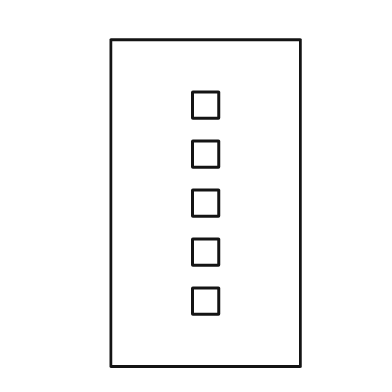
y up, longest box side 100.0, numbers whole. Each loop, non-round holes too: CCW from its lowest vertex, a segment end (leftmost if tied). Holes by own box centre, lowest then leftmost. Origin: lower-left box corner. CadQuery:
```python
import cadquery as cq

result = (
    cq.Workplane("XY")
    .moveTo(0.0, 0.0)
    .lineTo(58.0, 0.0)
    .lineTo(58.0, 100.0)
    .lineTo(0.0, 100.0)
    .close()
    .moveTo(25.0, 16.0)
    .lineTo(33.0, 16.0)
    .lineTo(33.0, 24.0)
    .lineTo(25.0, 24.0)
    .close()
    .moveTo(25.0, 31.0)
    .lineTo(33.0, 31.0)
    .lineTo(33.0, 39.0)
    .lineTo(25.0, 39.0)
    .close()
    .moveTo(25.0, 46.0)
    .lineTo(33.0, 46.0)
    .lineTo(33.0, 54.0)
    .lineTo(25.0, 54.0)
    .close()
    .moveTo(25.0, 61.0)
    .lineTo(33.0, 61.0)
    .lineTo(33.0, 69.0)
    .lineTo(25.0, 69.0)
    .close()
    .moveTo(25.0, 76.0)
    .lineTo(33.0, 76.0)
    .lineTo(33.0, 84.0)
    .lineTo(25.0, 84.0)
    .close()
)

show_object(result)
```